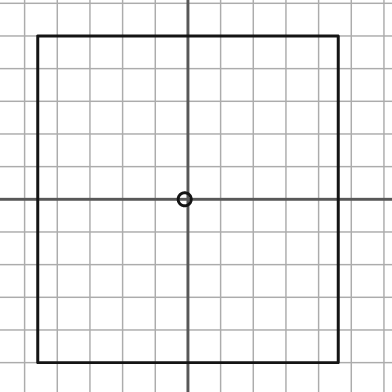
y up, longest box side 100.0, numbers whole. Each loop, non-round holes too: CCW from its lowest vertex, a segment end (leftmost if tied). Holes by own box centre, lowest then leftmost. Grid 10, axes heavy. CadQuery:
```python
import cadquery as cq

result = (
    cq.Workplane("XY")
    .moveTo(-46.0, -50.0)
    .lineTo(46.0, -50.0)
    .lineTo(46.0, 50.0)
    .lineTo(-46.0, 50.0)
    .close()
    .moveTo(-1.0, 0.0)
    .circle(2.0)
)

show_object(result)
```